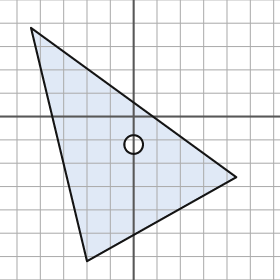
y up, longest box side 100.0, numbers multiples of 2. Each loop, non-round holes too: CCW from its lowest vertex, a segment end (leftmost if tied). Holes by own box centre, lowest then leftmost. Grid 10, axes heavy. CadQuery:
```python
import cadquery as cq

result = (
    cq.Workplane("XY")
    .moveTo(-20.0, -62.0)
    .lineTo(44.0, -26.0)
    .lineTo(-44.0, 38.0)
    .close()
    .moveTo(0.0, -12.0)
    .circle(4.0)
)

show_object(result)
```